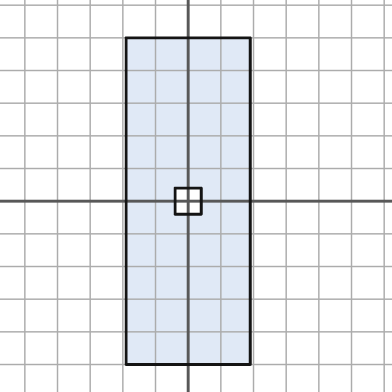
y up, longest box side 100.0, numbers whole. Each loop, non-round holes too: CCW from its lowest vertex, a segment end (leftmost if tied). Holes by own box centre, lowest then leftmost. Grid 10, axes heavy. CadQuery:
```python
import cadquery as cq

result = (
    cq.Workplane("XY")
    .moveTo(-19.0, -50.0)
    .lineTo(19.0, -50.0)
    .lineTo(19.0, 50.0)
    .lineTo(-19.0, 50.0)
    .close()
    .moveTo(-4.0, -4.0)
    .lineTo(4.0, -4.0)
    .lineTo(4.0, 4.0)
    .lineTo(-4.0, 4.0)
    .close()
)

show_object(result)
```